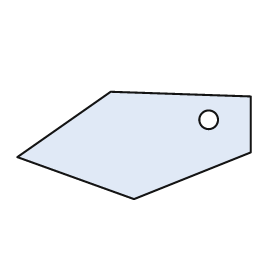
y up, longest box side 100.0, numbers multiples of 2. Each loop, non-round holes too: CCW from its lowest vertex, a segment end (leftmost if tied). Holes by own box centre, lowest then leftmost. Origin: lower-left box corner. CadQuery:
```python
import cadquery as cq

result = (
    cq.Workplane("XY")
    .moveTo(50.0, 0.0)
    .lineTo(100.0, 20.0)
    .lineTo(100.0, 44.0)
    .lineTo(40.0, 46.0)
    .lineTo(0.0, 18.0)
    .close()
    .moveTo(82.0, 34.0)
    .circle(4.0)
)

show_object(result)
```